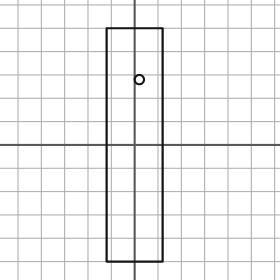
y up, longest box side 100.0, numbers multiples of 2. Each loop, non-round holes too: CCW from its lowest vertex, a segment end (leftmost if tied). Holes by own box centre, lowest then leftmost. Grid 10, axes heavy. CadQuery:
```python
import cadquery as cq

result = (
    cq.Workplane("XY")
    .moveTo(-12.0, -50.0)
    .lineTo(12.0, -50.0)
    .lineTo(12.0, 50.0)
    .lineTo(-12.0, 50.0)
    .close()
    .moveTo(2.0, 28.0)
    .circle(2.0)
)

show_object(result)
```